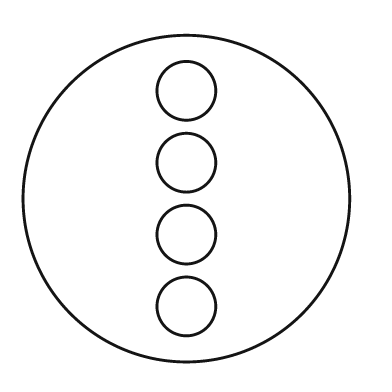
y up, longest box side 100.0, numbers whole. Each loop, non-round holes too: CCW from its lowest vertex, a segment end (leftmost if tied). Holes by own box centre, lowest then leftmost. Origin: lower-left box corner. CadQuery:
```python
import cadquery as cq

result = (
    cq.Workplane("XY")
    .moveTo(50.0, 50.0)
    .circle(50.0)
    .moveTo(50.0, 17.0)
    .circle(9.0)
    .moveTo(50.0, 39.0)
    .circle(9.0)
    .moveTo(50.0, 61.0)
    .circle(9.0)
    .moveTo(50.0, 83.0)
    .circle(9.0)
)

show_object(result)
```